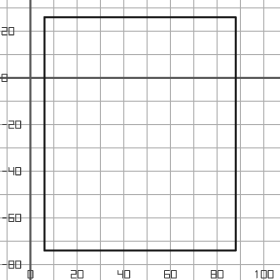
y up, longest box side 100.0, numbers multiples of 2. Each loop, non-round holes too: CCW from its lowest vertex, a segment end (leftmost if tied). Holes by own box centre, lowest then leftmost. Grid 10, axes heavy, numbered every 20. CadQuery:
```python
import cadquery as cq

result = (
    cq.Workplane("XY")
    .moveTo(6.0, -74.0)
    .lineTo(88.0, -74.0)
    .lineTo(88.0, 26.0)
    .lineTo(6.0, 26.0)
    .close()
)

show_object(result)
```